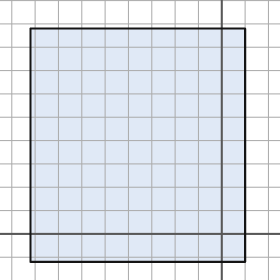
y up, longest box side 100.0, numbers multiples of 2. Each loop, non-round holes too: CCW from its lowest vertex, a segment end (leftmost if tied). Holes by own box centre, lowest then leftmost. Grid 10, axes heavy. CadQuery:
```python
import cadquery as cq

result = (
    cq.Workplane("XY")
    .moveTo(-82.0, -12.0)
    .lineTo(10.0, -12.0)
    .lineTo(10.0, 88.0)
    .lineTo(-82.0, 88.0)
    .close()
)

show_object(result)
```